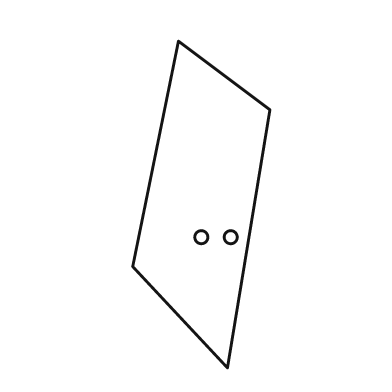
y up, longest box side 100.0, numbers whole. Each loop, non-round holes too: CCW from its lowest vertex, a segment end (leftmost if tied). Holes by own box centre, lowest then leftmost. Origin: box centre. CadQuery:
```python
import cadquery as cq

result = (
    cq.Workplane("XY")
    .moveTo(8.0, -50.0)
    .lineTo(21.0, 29.0)
    .lineTo(-7.0, 50.0)
    .lineTo(-21.0, -19.0)
    .close()
    .moveTo(0.0, -10.0)
    .circle(2.0)
    .moveTo(9.0, -10.0)
    .circle(2.0)
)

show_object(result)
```